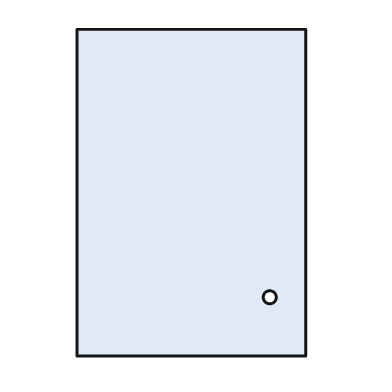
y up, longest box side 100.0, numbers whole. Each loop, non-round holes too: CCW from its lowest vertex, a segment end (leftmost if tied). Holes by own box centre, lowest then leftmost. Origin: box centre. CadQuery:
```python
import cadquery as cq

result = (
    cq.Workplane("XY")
    .moveTo(-35.0, -50.0)
    .lineTo(35.0, -50.0)
    .lineTo(35.0, 50.0)
    .lineTo(-35.0, 50.0)
    .close()
    .moveTo(24.0, -32.0)
    .circle(2.0)
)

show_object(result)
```